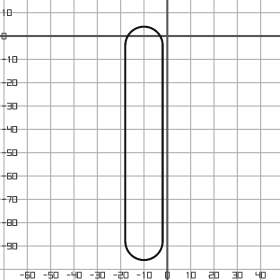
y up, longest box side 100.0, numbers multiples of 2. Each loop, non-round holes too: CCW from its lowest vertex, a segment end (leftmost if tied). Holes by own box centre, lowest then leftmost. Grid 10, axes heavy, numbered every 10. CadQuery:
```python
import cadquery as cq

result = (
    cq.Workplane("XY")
    .moveTo(-18.0, -88.0)
    .threePointArc((-10.0, -96.0), (-2.0, -88.0))
    .lineTo(-2.0, -4.0)
    .threePointArc((-10.0, 4.0), (-18.0, -4.0))
    .close()
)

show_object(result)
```